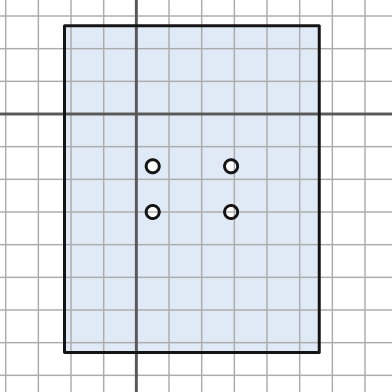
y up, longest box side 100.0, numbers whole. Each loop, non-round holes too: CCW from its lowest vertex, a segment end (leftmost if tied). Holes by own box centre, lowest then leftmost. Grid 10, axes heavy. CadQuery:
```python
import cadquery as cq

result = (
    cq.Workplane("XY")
    .moveTo(-22.0, -73.0)
    .lineTo(56.0, -73.0)
    .lineTo(56.0, 27.0)
    .lineTo(-22.0, 27.0)
    .close()
    .moveTo(5.0, -30.0)
    .circle(2.0)
    .moveTo(29.0, -30.0)
    .circle(2.0)
    .moveTo(5.0, -16.0)
    .circle(2.0)
    .moveTo(29.0, -16.0)
    .circle(2.0)
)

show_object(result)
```